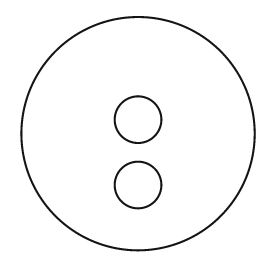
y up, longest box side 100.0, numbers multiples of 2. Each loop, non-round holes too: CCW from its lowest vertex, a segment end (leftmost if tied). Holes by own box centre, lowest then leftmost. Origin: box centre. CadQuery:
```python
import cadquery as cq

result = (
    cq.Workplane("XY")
    .moveTo(0.0, 0.0)
    .circle(50.0)
    .moveTo(0.0, -22.0)
    .circle(10.0)
    .moveTo(0.0, 6.0)
    .circle(10.0)
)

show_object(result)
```